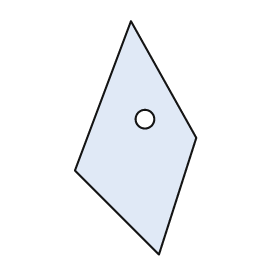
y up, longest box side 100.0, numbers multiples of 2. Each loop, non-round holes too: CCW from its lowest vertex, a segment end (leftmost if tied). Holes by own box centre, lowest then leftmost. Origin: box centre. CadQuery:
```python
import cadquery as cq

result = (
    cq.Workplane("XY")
    .moveTo(10.0, -50.0)
    .lineTo(26.0, 0.0)
    .lineTo(-2.0, 50.0)
    .lineTo(-26.0, -14.0)
    .close()
    .moveTo(4.0, 8.0)
    .circle(4.0)
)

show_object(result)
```